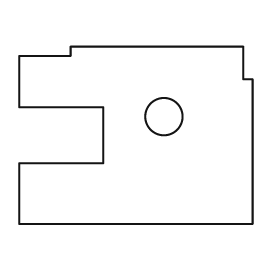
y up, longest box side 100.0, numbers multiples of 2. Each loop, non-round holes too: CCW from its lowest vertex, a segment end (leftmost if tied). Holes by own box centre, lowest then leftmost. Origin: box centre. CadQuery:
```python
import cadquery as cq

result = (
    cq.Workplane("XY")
    .moveTo(-50.0, -38.0)
    .lineTo(50.0, -38.0)
    .lineTo(50.0, 24.0)
    .lineTo(46.0, 24.0)
    .lineTo(46.0, 38.0)
    .lineTo(-28.0, 38.0)
    .lineTo(-28.0, 34.0)
    .lineTo(-50.0, 34.0)
    .lineTo(-50.0, 12.0)
    .lineTo(-14.0, 12.0)
    .lineTo(-14.0, -12.0)
    .lineTo(-50.0, -12.0)
    .close()
    .moveTo(12.0, 8.0)
    .circle(8.0)
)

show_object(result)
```